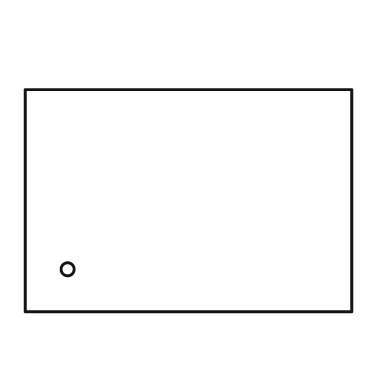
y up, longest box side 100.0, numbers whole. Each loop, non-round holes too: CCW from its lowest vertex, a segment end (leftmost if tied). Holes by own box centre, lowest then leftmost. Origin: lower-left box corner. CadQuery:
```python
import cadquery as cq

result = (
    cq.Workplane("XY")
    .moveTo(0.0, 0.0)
    .lineTo(100.0, 0.0)
    .lineTo(100.0, 68.0)
    .lineTo(0.0, 68.0)
    .close()
    .moveTo(13.0, 13.0)
    .circle(2.0)
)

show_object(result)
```